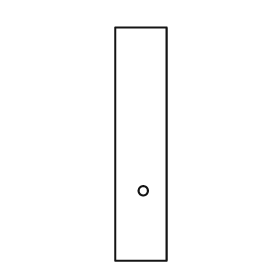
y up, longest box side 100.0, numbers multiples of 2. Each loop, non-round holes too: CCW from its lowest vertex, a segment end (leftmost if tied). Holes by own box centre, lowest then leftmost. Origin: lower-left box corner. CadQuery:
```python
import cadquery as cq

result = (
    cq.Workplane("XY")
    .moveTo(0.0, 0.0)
    .lineTo(22.0, 0.0)
    .lineTo(22.0, 100.0)
    .lineTo(0.0, 100.0)
    .close()
    .moveTo(12.0, 30.0)
    .circle(2.0)
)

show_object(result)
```